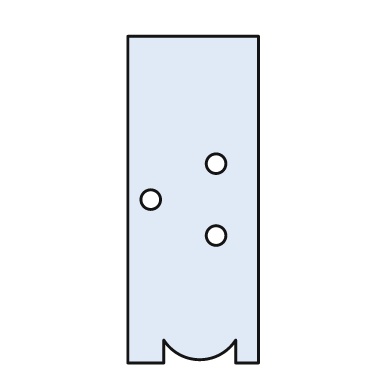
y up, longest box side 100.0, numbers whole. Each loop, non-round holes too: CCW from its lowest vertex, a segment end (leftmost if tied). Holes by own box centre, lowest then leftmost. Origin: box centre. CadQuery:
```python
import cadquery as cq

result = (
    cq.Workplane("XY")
    .moveTo(-20.0, -50.0)
    .lineTo(-9.0, -50.0)
    .lineTo(-9.0, -43.0)
    .threePointArc((2.0, -49.0), (13.0, -43.0))
    .lineTo(13.0, -50.0)
    .lineTo(20.0, -50.0)
    .lineTo(20.0, 50.0)
    .lineTo(-20.0, 50.0)
    .close()
    .moveTo(7.0, -11.0)
    .circle(3.0)
    .moveTo(-13.0, 0.0)
    .circle(3.0)
    .moveTo(7.0, 11.0)
    .circle(3.0)
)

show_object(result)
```